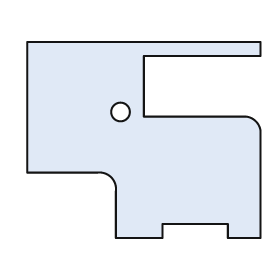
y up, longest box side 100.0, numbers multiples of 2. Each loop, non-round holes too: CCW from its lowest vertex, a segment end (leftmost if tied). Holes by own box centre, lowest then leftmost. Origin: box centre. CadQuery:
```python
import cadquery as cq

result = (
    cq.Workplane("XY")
    .moveTo(-12.0, -42.0)
    .lineTo(8.0, -42.0)
    .lineTo(8.0, -36.0)
    .lineTo(36.0, -36.0)
    .lineTo(36.0, -42.0)
    .lineTo(50.0, -42.0)
    .lineTo(50.0, 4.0)
    .threePointArc((48.0, 8.0), (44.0, 10.0))
    .lineTo(0.0, 10.0)
    .lineTo(0.0, 36.0)
    .lineTo(50.0, 36.0)
    .lineTo(50.0, 42.0)
    .lineTo(-50.0, 42.0)
    .lineTo(-50.0, -14.0)
    .lineTo(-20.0, -14.0)
    .threePointArc((-14.0, -16.0), (-12.0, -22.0))
    .close()
    .moveTo(-10.0, 12.0)
    .circle(4.0)
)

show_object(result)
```